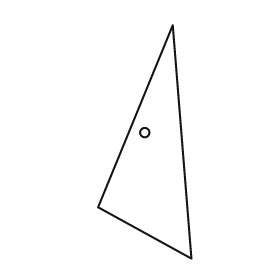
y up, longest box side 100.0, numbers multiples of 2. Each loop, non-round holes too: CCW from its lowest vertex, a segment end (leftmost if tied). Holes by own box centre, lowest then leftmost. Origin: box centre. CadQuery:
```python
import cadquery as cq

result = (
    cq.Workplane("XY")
    .moveTo(20.0, -50.0)
    .lineTo(12.0, 50.0)
    .lineTo(-20.0, -28.0)
    .close()
    .moveTo(0.0, 4.0)
    .circle(2.0)
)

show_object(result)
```